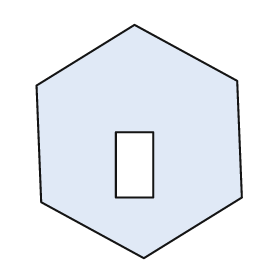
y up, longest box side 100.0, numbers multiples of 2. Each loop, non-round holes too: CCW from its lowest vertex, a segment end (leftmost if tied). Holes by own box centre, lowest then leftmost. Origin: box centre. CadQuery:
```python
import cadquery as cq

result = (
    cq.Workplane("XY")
    .moveTo(2.0, -50.0)
    .lineTo(44.0, -24.0)
    .lineTo(42.0, 26.0)
    .lineTo(-2.0, 50.0)
    .lineTo(-44.0, 24.0)
    .lineTo(-42.0, -26.0)
    .close()
    .moveTo(-10.0, -24.0)
    .lineTo(6.0, -24.0)
    .lineTo(6.0, 4.0)
    .lineTo(-10.0, 4.0)
    .close()
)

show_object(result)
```